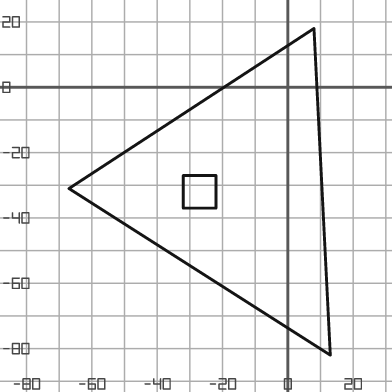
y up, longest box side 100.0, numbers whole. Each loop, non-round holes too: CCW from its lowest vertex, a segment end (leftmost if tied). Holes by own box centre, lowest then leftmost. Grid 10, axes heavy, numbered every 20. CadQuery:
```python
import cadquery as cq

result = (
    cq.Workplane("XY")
    .moveTo(13.0, -82.0)
    .lineTo(8.0, 18.0)
    .lineTo(-67.0, -31.0)
    .close()
    .moveTo(-32.0, -37.0)
    .lineTo(-22.0, -37.0)
    .lineTo(-22.0, -27.0)
    .lineTo(-32.0, -27.0)
    .close()
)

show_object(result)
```